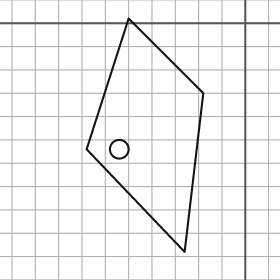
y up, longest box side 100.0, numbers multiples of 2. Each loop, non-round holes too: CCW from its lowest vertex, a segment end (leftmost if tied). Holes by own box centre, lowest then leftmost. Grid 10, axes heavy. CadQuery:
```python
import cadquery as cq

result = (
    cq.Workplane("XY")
    .moveTo(-26.0, -98.0)
    .lineTo(-18.0, -30.0)
    .lineTo(-50.0, 2.0)
    .lineTo(-68.0, -54.0)
    .close()
    .moveTo(-54.0, -54.0)
    .circle(4.0)
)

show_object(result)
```